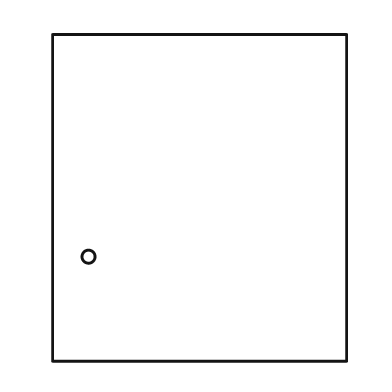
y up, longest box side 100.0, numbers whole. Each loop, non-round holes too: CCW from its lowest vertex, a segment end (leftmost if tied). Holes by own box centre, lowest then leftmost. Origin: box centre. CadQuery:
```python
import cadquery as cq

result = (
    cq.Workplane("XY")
    .moveTo(-45.0, -50.0)
    .lineTo(45.0, -50.0)
    .lineTo(45.0, 50.0)
    .lineTo(-45.0, 50.0)
    .close()
    .moveTo(-34.0, -18.0)
    .circle(2.0)
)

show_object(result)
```